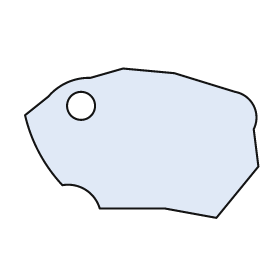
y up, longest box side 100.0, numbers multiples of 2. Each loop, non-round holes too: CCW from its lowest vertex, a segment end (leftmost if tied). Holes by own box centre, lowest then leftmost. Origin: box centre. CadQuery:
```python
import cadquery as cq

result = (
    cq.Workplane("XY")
    .moveTo(32.0, -32.0)
    .lineTo(50.0, -10.0)
    .lineTo(48.0, 6.0)
    .threePointArc((48.0, 16.0), (40.0, 22.0))
    .lineTo(14.0, 30.0)
    .lineTo(-8.0, 32.0)
    .lineTo(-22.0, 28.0)
    .threePointArc((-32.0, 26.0), (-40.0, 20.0))
    .lineTo(-50.0, 12.0)
    .threePointArc((-44.0, -4.0), (-34.0, -18.0))
    .threePointArc((-24.0, -20.0), (-18.0, -28.0))
    .lineTo(10.0, -28.0)
    .close()
    .moveTo(-26.0, 16.0)
    .circle(6.0)
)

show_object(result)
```